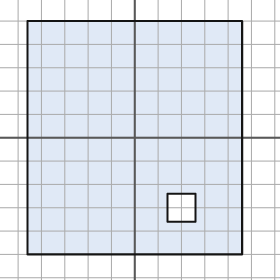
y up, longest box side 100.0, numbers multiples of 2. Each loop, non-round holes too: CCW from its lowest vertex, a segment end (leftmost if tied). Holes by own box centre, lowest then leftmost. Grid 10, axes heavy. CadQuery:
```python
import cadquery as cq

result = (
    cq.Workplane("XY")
    .moveTo(-46.0, -50.0)
    .lineTo(46.0, -50.0)
    .lineTo(46.0, 50.0)
    .lineTo(-46.0, 50.0)
    .close()
    .moveTo(14.0, -36.0)
    .lineTo(26.0, -36.0)
    .lineTo(26.0, -24.0)
    .lineTo(14.0, -24.0)
    .close()
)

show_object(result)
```